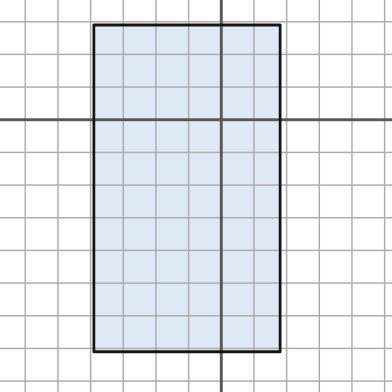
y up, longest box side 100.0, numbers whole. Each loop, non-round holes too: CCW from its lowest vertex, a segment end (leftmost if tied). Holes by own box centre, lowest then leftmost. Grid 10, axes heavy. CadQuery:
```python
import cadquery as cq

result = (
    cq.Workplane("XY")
    .moveTo(-39.0, -71.0)
    .lineTo(18.0, -71.0)
    .lineTo(18.0, 29.0)
    .lineTo(-39.0, 29.0)
    .close()
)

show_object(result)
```